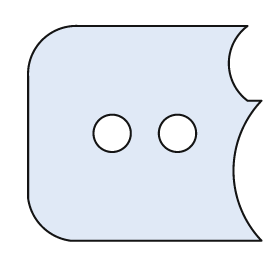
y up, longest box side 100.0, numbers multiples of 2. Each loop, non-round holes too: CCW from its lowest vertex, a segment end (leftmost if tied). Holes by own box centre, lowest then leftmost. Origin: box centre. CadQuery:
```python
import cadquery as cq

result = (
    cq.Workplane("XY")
    .moveTo(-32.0, -46.0)
    .lineTo(50.0, -46.0)
    .threePointArc((38.0, -16.0), (50.0, 14.0))
    .lineTo(44.0, 14.0)
    .threePointArc((36.0, 30.0), (44.0, 46.0))
    .lineTo(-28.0, 46.0)
    .threePointArc((-44.0, 40.0), (-50.0, 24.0))
    .lineTo(-50.0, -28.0)
    .threePointArc((-44.0, -40.0), (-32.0, -46.0))
    .close()
    .moveTo(-14.0, 0.0)
    .circle(8.0)
    .moveTo(14.0, 0.0)
    .circle(8.0)
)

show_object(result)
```